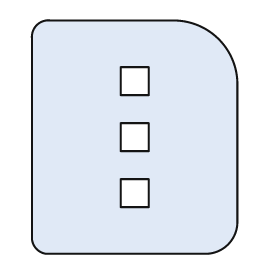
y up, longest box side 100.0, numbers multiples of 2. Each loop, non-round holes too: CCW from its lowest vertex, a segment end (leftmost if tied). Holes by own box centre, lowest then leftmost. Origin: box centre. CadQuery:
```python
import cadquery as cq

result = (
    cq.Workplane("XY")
    .moveTo(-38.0, -50.0)
    .lineTo(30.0, -50.0)
    .threePointArc((40.0, -46.0), (44.0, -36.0))
    .lineTo(44.0, 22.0)
    .threePointArc((36.0, 42.0), (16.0, 50.0))
    .lineTo(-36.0, 50.0)
    .threePointArc((-42.0, 48.0), (-44.0, 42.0))
    .lineTo(-44.0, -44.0)
    .threePointArc((-42.0, -48.0), (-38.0, -50.0))
    .close()
    .moveTo(-6.0, -30.0)
    .lineTo(6.0, -30.0)
    .lineTo(6.0, -18.0)
    .lineTo(-6.0, -18.0)
    .close()
    .moveTo(-6.0, -6.0)
    .lineTo(6.0, -6.0)
    .lineTo(6.0, 6.0)
    .lineTo(-6.0, 6.0)
    .close()
    .moveTo(-6.0, 18.0)
    .lineTo(6.0, 18.0)
    .lineTo(6.0, 30.0)
    .lineTo(-6.0, 30.0)
    .close()
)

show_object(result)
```